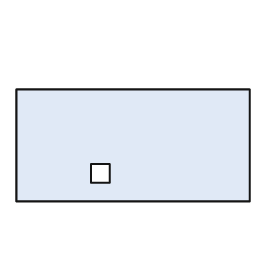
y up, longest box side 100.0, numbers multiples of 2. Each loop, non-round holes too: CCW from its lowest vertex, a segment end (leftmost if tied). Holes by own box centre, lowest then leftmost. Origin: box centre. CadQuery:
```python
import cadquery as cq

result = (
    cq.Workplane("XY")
    .moveTo(-50.0, -24.0)
    .lineTo(50.0, -24.0)
    .lineTo(50.0, 24.0)
    .lineTo(-50.0, 24.0)
    .close()
    .moveTo(-18.0, -16.0)
    .lineTo(-10.0, -16.0)
    .lineTo(-10.0, -8.0)
    .lineTo(-18.0, -8.0)
    .close()
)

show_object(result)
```